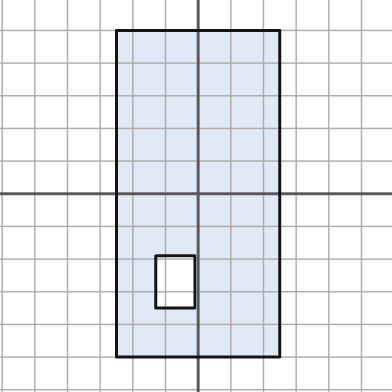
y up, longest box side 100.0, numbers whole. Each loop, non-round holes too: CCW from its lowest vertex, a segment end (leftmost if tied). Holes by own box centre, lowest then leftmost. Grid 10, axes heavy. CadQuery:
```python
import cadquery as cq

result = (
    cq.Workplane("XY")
    .moveTo(-25.0, -50.0)
    .lineTo(25.0, -50.0)
    .lineTo(25.0, 50.0)
    .lineTo(-25.0, 50.0)
    .close()
    .moveTo(-13.0, -35.0)
    .lineTo(-1.0, -35.0)
    .lineTo(-1.0, -19.0)
    .lineTo(-13.0, -19.0)
    .close()
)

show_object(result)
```